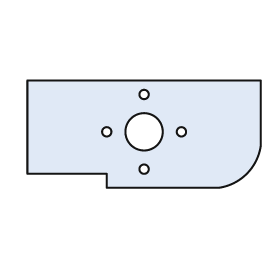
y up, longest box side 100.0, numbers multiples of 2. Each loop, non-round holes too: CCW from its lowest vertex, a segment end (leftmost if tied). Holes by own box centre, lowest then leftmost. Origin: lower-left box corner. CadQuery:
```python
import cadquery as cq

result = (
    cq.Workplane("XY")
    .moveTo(34.0, 0.0)
    .lineTo(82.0, 0.0)
    .threePointArc((94.0, 6.0), (100.0, 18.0))
    .lineTo(100.0, 46.0)
    .lineTo(0.0, 46.0)
    .lineTo(0.0, 6.0)
    .lineTo(34.0, 6.0)
    .close()
    .moveTo(50.0, 8.0)
    .circle(2.0)
    .moveTo(34.0, 24.0)
    .circle(2.0)
    .moveTo(50.0, 24.0)
    .circle(8.0)
    .moveTo(66.0, 24.0)
    .circle(2.0)
    .moveTo(50.0, 40.0)
    .circle(2.0)
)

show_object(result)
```